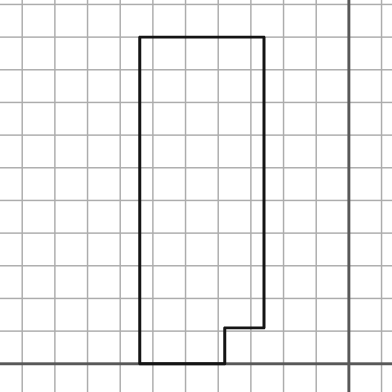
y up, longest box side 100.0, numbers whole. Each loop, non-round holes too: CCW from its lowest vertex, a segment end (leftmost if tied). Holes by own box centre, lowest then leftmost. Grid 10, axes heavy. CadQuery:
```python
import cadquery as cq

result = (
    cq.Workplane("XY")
    .moveTo(-64.0, 0.0)
    .lineTo(-38.0, 0.0)
    .lineTo(-38.0, 11.0)
    .lineTo(-26.0, 11.0)
    .lineTo(-26.0, 100.0)
    .lineTo(-64.0, 100.0)
    .close()
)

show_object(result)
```